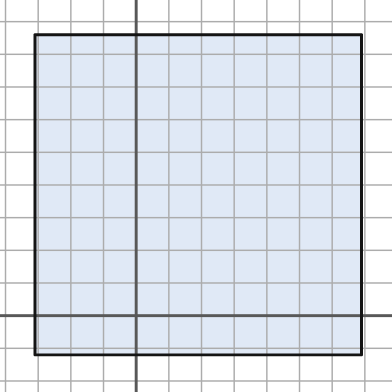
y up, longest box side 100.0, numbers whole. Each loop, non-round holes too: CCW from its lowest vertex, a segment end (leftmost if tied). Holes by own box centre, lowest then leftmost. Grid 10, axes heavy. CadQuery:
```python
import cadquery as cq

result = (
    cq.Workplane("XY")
    .moveTo(-31.0, -12.0)
    .lineTo(69.0, -12.0)
    .lineTo(69.0, 86.0)
    .lineTo(-31.0, 86.0)
    .close()
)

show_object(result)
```